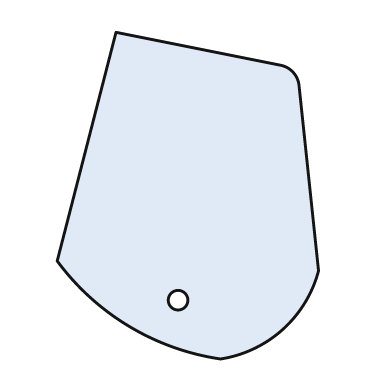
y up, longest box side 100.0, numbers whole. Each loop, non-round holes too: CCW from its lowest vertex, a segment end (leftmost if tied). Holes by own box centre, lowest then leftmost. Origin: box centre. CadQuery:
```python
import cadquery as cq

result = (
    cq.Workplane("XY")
    .moveTo(10.0, -50.0)
    .threePointArc((29.0, -41.0), (40.0, -23.0))
    .lineTo(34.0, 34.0)
    .threePointArc((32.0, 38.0), (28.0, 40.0))
    .lineTo(-22.0, 50.0)
    .lineTo(-40.0, -20.0)
    .threePointArc((-18.0, -40.0), (10.0, -50.0))
    .close()
    .moveTo(-3.0, -32.0)
    .circle(3.0)
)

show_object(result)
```